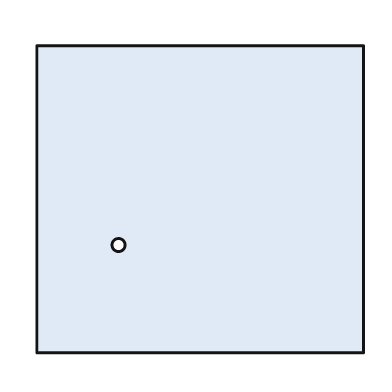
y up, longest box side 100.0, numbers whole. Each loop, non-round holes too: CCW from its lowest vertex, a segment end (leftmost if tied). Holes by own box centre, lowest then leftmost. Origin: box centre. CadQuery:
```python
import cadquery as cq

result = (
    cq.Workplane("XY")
    .moveTo(-50.0, -47.0)
    .lineTo(50.0, -47.0)
    .lineTo(50.0, 47.0)
    .lineTo(-50.0, 47.0)
    .close()
    .moveTo(-25.0, -14.0)
    .circle(2.0)
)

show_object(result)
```